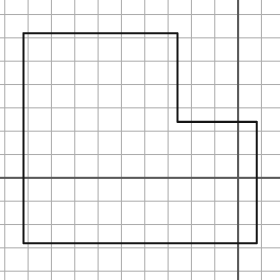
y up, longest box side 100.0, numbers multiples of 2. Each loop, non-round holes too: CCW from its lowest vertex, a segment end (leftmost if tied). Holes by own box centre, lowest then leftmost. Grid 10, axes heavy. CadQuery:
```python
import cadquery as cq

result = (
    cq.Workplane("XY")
    .moveTo(-92.0, -28.0)
    .lineTo(8.0, -28.0)
    .lineTo(8.0, 24.0)
    .lineTo(-26.0, 24.0)
    .lineTo(-26.0, 62.0)
    .lineTo(-92.0, 62.0)
    .close()
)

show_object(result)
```